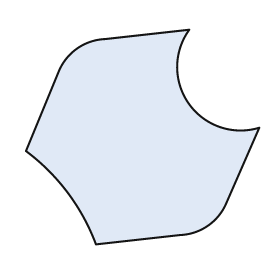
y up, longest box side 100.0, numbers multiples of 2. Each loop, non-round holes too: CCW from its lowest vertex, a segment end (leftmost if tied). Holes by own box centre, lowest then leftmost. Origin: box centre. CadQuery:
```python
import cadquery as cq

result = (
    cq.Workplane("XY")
    .moveTo(-20.0, -46.0)
    .lineTo(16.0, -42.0)
    .threePointArc((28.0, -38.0), (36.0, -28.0))
    .lineTo(50.0, 4.0)
    .threePointArc((20.0, 14.0), (20.0, 46.0))
    .lineTo(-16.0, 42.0)
    .threePointArc((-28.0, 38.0), (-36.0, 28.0))
    .lineTo(-50.0, -6.0)
    .threePointArc((-32.0, -24.0), (-20.0, -46.0))
    .close()
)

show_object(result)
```